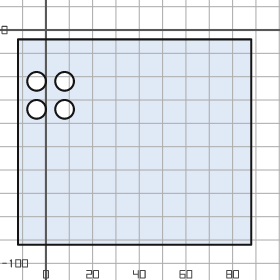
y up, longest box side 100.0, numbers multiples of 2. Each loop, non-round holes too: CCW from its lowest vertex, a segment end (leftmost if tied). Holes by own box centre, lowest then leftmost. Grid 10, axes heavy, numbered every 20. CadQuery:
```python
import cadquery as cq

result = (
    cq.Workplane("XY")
    .moveTo(-12.0, -92.0)
    .lineTo(88.0, -92.0)
    .lineTo(88.0, -4.0)
    .lineTo(-12.0, -4.0)
    .close()
    .moveTo(-4.0, -34.0)
    .circle(4.0)
    .moveTo(8.0, -34.0)
    .circle(4.0)
    .moveTo(-4.0, -22.0)
    .circle(4.0)
    .moveTo(8.0, -22.0)
    .circle(4.0)
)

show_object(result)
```